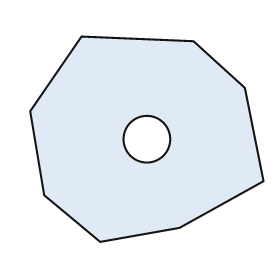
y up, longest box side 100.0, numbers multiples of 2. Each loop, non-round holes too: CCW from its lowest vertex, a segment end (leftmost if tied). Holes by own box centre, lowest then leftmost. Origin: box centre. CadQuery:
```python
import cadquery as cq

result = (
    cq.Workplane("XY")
    .moveTo(-20.0, -44.0)
    .lineTo(14.0, -38.0)
    .lineTo(50.0, -18.0)
    .lineTo(42.0, 22.0)
    .lineTo(20.0, 42.0)
    .lineTo(-28.0, 44.0)
    .lineTo(-50.0, 12.0)
    .lineTo(-44.0, -24.0)
    .close()
    .moveTo(0.0, 0.0)
    .circle(10.0)
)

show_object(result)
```